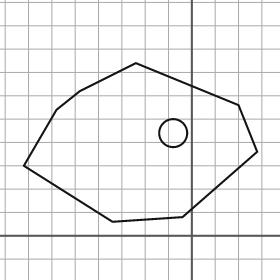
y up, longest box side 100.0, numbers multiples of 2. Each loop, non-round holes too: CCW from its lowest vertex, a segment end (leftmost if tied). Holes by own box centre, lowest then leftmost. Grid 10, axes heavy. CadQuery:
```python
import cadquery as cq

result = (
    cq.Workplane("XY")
    .moveTo(-34.0, 6.0)
    .lineTo(-4.0, 8.0)
    .lineTo(28.0, 36.0)
    .lineTo(20.0, 56.0)
    .lineTo(-24.0, 74.0)
    .lineTo(-48.0, 62.0)
    .lineTo(-58.0, 54.0)
    .lineTo(-72.0, 30.0)
    .close()
    .moveTo(-8.0, 44.0)
    .circle(6.0)
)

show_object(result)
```